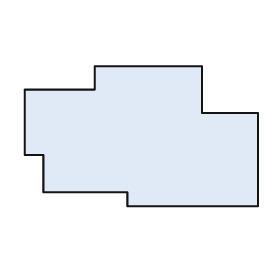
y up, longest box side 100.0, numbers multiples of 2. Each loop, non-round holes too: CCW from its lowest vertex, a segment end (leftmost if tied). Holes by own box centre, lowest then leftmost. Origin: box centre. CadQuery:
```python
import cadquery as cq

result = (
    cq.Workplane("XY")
    .moveTo(-6.0, -30.0)
    .lineTo(50.0, -30.0)
    .lineTo(50.0, 10.0)
    .lineTo(26.0, 10.0)
    .lineTo(26.0, 30.0)
    .lineTo(-20.0, 30.0)
    .lineTo(-20.0, 20.0)
    .lineTo(-50.0, 20.0)
    .lineTo(-50.0, -8.0)
    .lineTo(-42.0, -8.0)
    .lineTo(-42.0, -24.0)
    .lineTo(-6.0, -24.0)
    .close()
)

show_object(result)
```